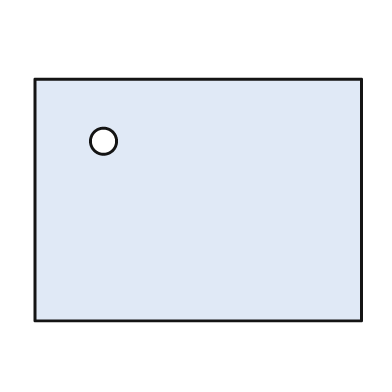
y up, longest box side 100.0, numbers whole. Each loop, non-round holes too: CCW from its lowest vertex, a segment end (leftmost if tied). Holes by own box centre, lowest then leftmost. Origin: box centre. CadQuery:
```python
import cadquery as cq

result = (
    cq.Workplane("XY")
    .moveTo(-50.0, -37.0)
    .lineTo(50.0, -37.0)
    .lineTo(50.0, 37.0)
    .lineTo(-50.0, 37.0)
    .close()
    .moveTo(-29.0, 18.0)
    .circle(4.0)
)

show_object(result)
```